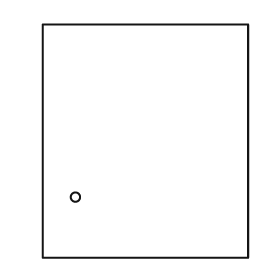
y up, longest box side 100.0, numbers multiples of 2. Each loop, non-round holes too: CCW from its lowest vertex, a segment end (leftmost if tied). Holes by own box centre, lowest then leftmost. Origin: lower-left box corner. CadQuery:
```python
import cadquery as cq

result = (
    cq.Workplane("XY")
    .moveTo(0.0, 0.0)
    .lineTo(88.0, 0.0)
    .lineTo(88.0, 100.0)
    .lineTo(0.0, 100.0)
    .close()
    .moveTo(14.0, 26.0)
    .circle(2.0)
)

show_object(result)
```